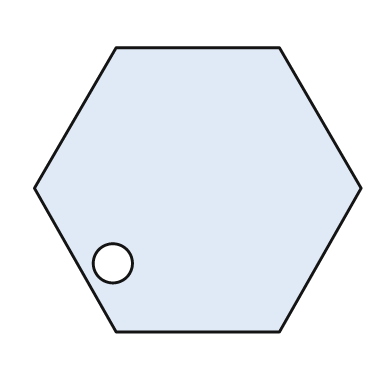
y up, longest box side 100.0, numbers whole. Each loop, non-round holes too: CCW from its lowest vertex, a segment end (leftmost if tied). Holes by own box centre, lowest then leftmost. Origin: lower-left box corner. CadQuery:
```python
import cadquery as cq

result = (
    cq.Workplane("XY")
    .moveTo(25.0, 0.0)
    .lineTo(75.0, 0.0)
    .lineTo(100.0, 44.0)
    .lineTo(75.0, 87.0)
    .lineTo(25.0, 87.0)
    .lineTo(0.0, 44.0)
    .close()
    .moveTo(24.0, 21.0)
    .circle(6.0)
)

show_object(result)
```